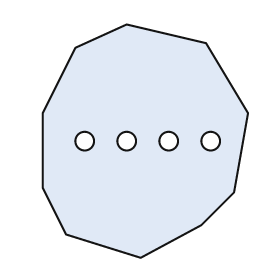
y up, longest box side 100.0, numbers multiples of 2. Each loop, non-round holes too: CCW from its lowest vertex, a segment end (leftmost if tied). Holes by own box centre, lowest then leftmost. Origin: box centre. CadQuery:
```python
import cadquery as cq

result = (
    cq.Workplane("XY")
    .moveTo(-2.0, -50.0)
    .lineTo(24.0, -36.0)
    .lineTo(38.0, -22.0)
    .lineTo(44.0, 12.0)
    .lineTo(26.0, 42.0)
    .lineTo(-8.0, 50.0)
    .lineTo(-30.0, 40.0)
    .lineTo(-44.0, 12.0)
    .lineTo(-44.0, -20.0)
    .lineTo(-34.0, -40.0)
    .close()
    .moveTo(-26.0, 0.0)
    .circle(4.0)
    .moveTo(-8.0, 0.0)
    .circle(4.0)
    .moveTo(10.0, 0.0)
    .circle(4.0)
    .moveTo(28.0, 0.0)
    .circle(4.0)
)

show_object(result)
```